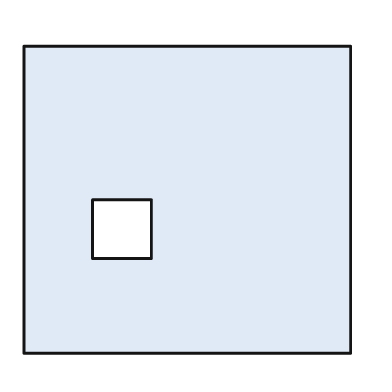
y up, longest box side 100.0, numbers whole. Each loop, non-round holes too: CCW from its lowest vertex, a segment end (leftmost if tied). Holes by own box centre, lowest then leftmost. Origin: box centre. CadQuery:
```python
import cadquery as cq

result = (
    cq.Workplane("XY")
    .moveTo(-50.0, -47.0)
    .lineTo(50.0, -47.0)
    .lineTo(50.0, 47.0)
    .lineTo(-50.0, 47.0)
    .close()
    .moveTo(-29.0, -18.0)
    .lineTo(-11.0, -18.0)
    .lineTo(-11.0, 0.0)
    .lineTo(-29.0, 0.0)
    .close()
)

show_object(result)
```